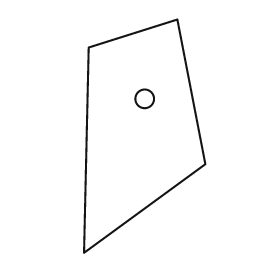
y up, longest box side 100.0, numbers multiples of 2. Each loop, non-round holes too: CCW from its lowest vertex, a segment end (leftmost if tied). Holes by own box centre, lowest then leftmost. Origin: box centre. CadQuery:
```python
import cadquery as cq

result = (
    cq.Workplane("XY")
    .moveTo(-26.0, -50.0)
    .lineTo(26.0, -12.0)
    .lineTo(14.0, 50.0)
    .lineTo(-24.0, 38.0)
    .close()
    .moveTo(0.0, 16.0)
    .circle(4.0)
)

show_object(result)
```